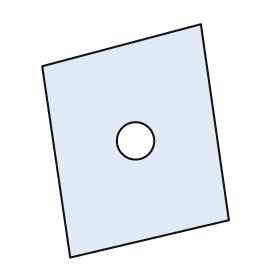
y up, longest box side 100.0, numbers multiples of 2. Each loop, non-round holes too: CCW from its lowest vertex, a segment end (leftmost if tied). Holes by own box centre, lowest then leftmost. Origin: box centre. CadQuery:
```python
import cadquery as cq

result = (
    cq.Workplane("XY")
    .moveTo(-28.0, -50.0)
    .lineTo(40.0, -34.0)
    .lineTo(28.0, 50.0)
    .lineTo(-40.0, 32.0)
    .close()
    .moveTo(0.0, 0.0)
    .circle(8.0)
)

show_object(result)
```